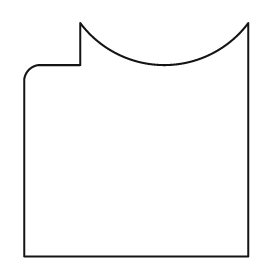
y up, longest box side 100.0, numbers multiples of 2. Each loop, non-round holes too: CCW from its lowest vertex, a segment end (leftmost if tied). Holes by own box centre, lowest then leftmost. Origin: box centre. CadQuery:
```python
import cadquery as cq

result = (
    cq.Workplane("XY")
    .moveTo(-48.0, -50.0)
    .lineTo(48.0, -50.0)
    .lineTo(48.0, 50.0)
    .threePointArc((12.0, 32.0), (-24.0, 50.0))
    .lineTo(-24.0, 32.0)
    .lineTo(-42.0, 32.0)
    .threePointArc((-46.0, 30.0), (-48.0, 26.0))
    .close()
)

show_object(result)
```